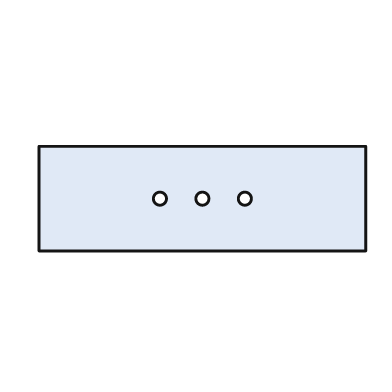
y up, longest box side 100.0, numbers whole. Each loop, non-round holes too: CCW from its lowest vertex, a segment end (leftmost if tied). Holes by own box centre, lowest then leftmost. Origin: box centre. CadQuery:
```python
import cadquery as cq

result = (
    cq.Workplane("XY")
    .moveTo(-50.0, -16.0)
    .lineTo(50.0, -16.0)
    .lineTo(50.0, 16.0)
    .lineTo(-50.0, 16.0)
    .close()
    .moveTo(-13.0, 0.0)
    .circle(2.0)
    .moveTo(0.0, 0.0)
    .circle(2.0)
    .moveTo(13.0, 0.0)
    .circle(2.0)
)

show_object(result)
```